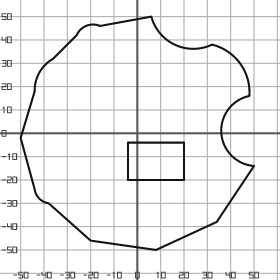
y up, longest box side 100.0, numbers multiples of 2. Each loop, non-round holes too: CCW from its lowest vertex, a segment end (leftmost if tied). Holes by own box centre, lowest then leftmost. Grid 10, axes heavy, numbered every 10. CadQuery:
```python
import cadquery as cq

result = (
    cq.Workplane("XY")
    .moveTo(8.0, -50.0)
    .lineTo(34.0, -38.0)
    .lineTo(50.0, -14.0)
    .threePointArc((36.0, 0.0), (48.0, 16.0))
    .threePointArc((44.0, 30.0), (32.0, 38.0))
    .threePointArc((16.0, 38.0), (6.0, 50.0))
    .lineTo(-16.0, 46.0)
    .threePointArc((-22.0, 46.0), (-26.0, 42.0))
    .lineTo(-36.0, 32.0)
    .threePointArc((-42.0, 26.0), (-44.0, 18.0))
    .lineTo(-50.0, -2.0)
    .lineTo(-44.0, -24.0)
    .threePointArc((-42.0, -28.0), (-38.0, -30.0))
    .lineTo(-20.0, -46.0)
    .close()
    .moveTo(-4.0, -20.0)
    .lineTo(20.0, -20.0)
    .lineTo(20.0, -4.0)
    .lineTo(-4.0, -4.0)
    .close()
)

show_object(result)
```